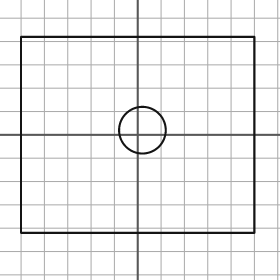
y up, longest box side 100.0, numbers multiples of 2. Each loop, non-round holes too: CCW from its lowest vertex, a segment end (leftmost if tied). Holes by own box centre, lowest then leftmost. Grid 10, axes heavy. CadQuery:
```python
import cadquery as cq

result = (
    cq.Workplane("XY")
    .moveTo(-50.0, -42.0)
    .lineTo(50.0, -42.0)
    .lineTo(50.0, 42.0)
    .lineTo(-50.0, 42.0)
    .close()
    .moveTo(2.0, 2.0)
    .circle(10.0)
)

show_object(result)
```